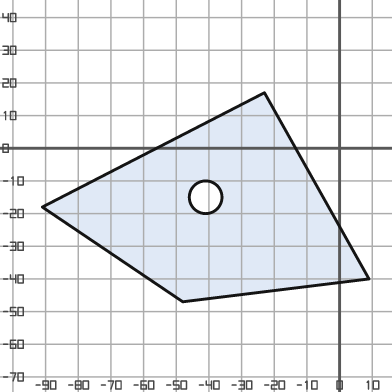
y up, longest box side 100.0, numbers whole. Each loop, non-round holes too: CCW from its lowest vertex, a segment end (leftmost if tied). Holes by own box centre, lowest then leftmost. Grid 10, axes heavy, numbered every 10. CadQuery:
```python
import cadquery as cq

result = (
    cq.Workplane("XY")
    .moveTo(-48.0, -47.0)
    .lineTo(9.0, -40.0)
    .lineTo(-23.0, 17.0)
    .lineTo(-91.0, -18.0)
    .close()
    .moveTo(-41.0, -15.0)
    .circle(5.0)
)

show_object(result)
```